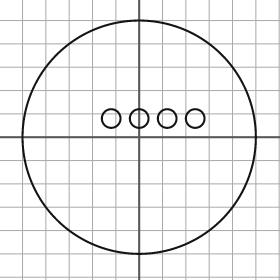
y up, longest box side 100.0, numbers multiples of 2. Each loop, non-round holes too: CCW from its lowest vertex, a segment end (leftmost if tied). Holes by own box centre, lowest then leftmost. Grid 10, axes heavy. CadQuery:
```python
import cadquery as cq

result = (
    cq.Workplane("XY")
    .moveTo(0.0, 0.0)
    .circle(50.0)
    .moveTo(-12.0, 8.0)
    .circle(4.0)
    .moveTo(0.0, 8.0)
    .circle(4.0)
    .moveTo(12.0, 8.0)
    .circle(4.0)
    .moveTo(24.0, 8.0)
    .circle(4.0)
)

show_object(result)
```